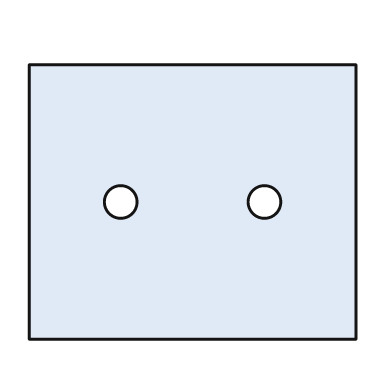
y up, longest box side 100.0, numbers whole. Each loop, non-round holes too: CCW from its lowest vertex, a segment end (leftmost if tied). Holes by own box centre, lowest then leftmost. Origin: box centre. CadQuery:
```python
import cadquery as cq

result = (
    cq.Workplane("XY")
    .moveTo(-50.0, -42.0)
    .lineTo(50.0, -42.0)
    .lineTo(50.0, 42.0)
    .lineTo(-50.0, 42.0)
    .close()
    .moveTo(-22.0, 0.0)
    .circle(5.0)
    .moveTo(22.0, 0.0)
    .circle(5.0)
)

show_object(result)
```